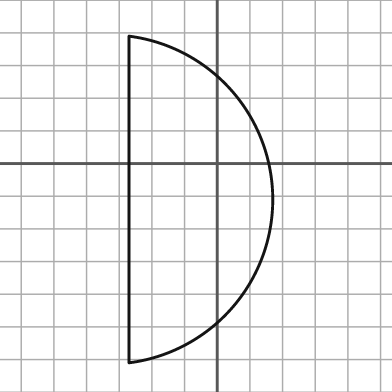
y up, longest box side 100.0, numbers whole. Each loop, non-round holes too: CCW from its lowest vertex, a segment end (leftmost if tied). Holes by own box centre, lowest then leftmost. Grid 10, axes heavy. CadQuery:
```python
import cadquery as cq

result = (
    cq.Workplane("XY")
    .moveTo(-27.0, -61.0)
    .threePointArc((17.0, -11.0), (-27.0, 39.0))
    .close()
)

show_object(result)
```